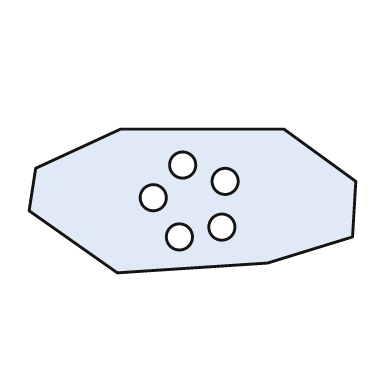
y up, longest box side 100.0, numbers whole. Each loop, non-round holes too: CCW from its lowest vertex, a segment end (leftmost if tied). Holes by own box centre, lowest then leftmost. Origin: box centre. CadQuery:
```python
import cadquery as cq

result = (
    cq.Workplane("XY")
    .moveTo(-23.0, -22.0)
    .lineTo(23.0, -19.0)
    .lineTo(49.0, -11.0)
    .lineTo(50.0, 6.0)
    .lineTo(28.0, 22.0)
    .lineTo(-22.0, 22.0)
    .lineTo(-48.0, 10.0)
    .lineTo(-50.0, -3.0)
    .close()
    .moveTo(-4.0, -11.0)
    .circle(4.0)
    .moveTo(9.0, -8.0)
    .circle(4.0)
    .moveTo(-12.0, 1.0)
    .circle(4.0)
    .moveTo(10.0, 6.0)
    .circle(4.0)
    .moveTo(-3.0, 11.0)
    .circle(4.0)
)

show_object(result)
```